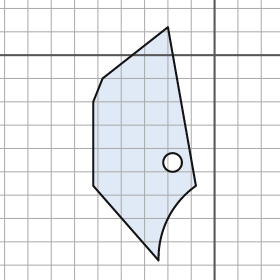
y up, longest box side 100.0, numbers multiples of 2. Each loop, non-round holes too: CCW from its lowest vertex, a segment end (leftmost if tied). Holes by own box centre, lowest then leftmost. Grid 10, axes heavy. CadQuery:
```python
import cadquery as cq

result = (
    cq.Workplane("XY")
    .moveTo(-24.0, -88.0)
    .threePointArc((-20.0, -70.0), (-8.0, -56.0))
    .lineTo(-20.0, 12.0)
    .lineTo(-48.0, -10.0)
    .lineTo(-52.0, -20.0)
    .lineTo(-52.0, -56.0)
    .close()
    .moveTo(-18.0, -46.0)
    .circle(4.0)
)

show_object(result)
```